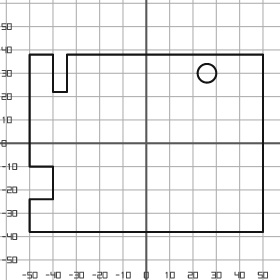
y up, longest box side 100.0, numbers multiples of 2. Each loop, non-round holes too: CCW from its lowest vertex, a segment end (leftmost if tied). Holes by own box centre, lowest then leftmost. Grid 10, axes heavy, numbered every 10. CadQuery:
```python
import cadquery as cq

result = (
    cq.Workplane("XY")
    .moveTo(-50.0, -38.0)
    .lineTo(50.0, -38.0)
    .lineTo(50.0, 38.0)
    .lineTo(-34.0, 38.0)
    .lineTo(-34.0, 22.0)
    .lineTo(-40.0, 22.0)
    .lineTo(-40.0, 38.0)
    .lineTo(-50.0, 38.0)
    .lineTo(-50.0, -10.0)
    .lineTo(-40.0, -10.0)
    .lineTo(-40.0, -24.0)
    .lineTo(-50.0, -24.0)
    .close()
    .moveTo(26.0, 30.0)
    .circle(4.0)
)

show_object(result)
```